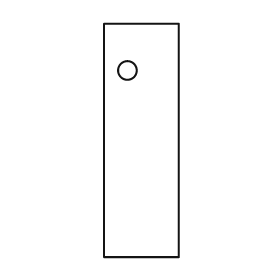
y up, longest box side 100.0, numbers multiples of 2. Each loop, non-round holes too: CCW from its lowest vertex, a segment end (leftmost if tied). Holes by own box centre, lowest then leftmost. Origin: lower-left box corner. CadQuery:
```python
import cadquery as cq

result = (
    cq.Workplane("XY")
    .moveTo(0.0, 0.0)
    .lineTo(32.0, 0.0)
    .lineTo(32.0, 100.0)
    .lineTo(0.0, 100.0)
    .close()
    .moveTo(10.0, 80.0)
    .circle(4.0)
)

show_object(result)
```